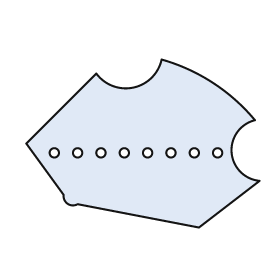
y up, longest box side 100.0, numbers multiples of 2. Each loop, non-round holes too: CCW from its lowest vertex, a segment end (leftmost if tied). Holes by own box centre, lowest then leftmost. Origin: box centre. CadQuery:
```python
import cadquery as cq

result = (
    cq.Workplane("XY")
    .moveTo(24.0, -36.0)
    .lineTo(50.0, -16.0)
    .threePointArc((38.0, -4.0), (48.0, 10.0))
    .threePointArc((30.0, 26.0), (8.0, 36.0))
    .threePointArc((-4.0, 24.0), (-20.0, 30.0))
    .lineTo(-50.0, 0.0)
    .lineTo(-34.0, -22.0)
    .threePointArc((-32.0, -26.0), (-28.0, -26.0))
    .close()
    .moveTo(-38.0, -4.0)
    .circle(2.0)
    .moveTo(-28.0, -4.0)
    .circle(2.0)
    .moveTo(-18.0, -4.0)
    .circle(2.0)
    .moveTo(-8.0, -4.0)
    .circle(2.0)
    .moveTo(2.0, -4.0)
    .circle(2.0)
    .moveTo(12.0, -4.0)
    .circle(2.0)
    .moveTo(22.0, -4.0)
    .circle(2.0)
    .moveTo(32.0, -4.0)
    .circle(2.0)
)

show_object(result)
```